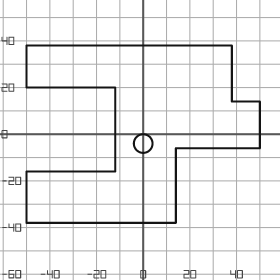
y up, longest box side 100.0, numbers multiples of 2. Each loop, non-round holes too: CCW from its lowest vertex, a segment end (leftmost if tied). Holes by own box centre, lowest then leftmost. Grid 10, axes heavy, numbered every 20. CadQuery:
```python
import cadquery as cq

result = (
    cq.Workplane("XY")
    .moveTo(-50.0, -38.0)
    .lineTo(14.0, -38.0)
    .lineTo(14.0, -6.0)
    .lineTo(50.0, -6.0)
    .lineTo(50.0, 14.0)
    .lineTo(38.0, 14.0)
    .lineTo(38.0, 38.0)
    .lineTo(-50.0, 38.0)
    .lineTo(-50.0, 20.0)
    .lineTo(-12.0, 20.0)
    .lineTo(-12.0, -16.0)
    .lineTo(-50.0, -16.0)
    .close()
    .moveTo(0.0, -4.0)
    .circle(4.0)
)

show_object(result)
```